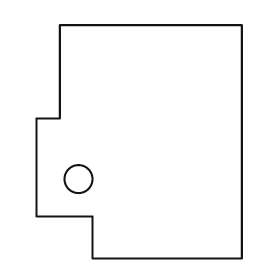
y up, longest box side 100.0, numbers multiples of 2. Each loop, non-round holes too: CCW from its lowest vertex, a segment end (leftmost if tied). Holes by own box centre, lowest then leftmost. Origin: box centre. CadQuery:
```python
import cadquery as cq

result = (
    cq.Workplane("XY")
    .moveTo(-20.0, -50.0)
    .lineTo(44.0, -50.0)
    .lineTo(44.0, 50.0)
    .lineTo(-34.0, 50.0)
    .lineTo(-34.0, 10.0)
    .lineTo(-44.0, 10.0)
    .lineTo(-44.0, -32.0)
    .lineTo(-20.0, -32.0)
    .close()
    .moveTo(-26.0, -16.0)
    .circle(6.0)
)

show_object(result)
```